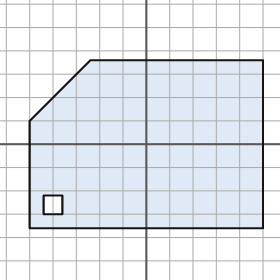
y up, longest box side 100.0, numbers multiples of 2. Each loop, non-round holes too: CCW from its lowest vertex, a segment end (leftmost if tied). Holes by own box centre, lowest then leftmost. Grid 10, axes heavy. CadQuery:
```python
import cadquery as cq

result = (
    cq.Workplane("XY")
    .moveTo(-50.0, -36.0)
    .lineTo(50.0, -36.0)
    .lineTo(50.0, 36.0)
    .lineTo(-24.0, 36.0)
    .lineTo(-50.0, 10.0)
    .close()
    .moveTo(-44.0, -30.0)
    .lineTo(-36.0, -30.0)
    .lineTo(-36.0, -22.0)
    .lineTo(-44.0, -22.0)
    .close()
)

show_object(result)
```